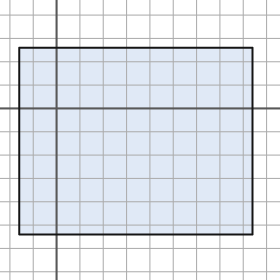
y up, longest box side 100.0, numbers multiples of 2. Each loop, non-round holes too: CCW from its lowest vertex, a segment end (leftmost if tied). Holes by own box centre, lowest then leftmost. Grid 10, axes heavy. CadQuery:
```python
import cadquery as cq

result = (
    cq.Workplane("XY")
    .moveTo(-16.0, -54.0)
    .lineTo(84.0, -54.0)
    .lineTo(84.0, 26.0)
    .lineTo(-16.0, 26.0)
    .close()
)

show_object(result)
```